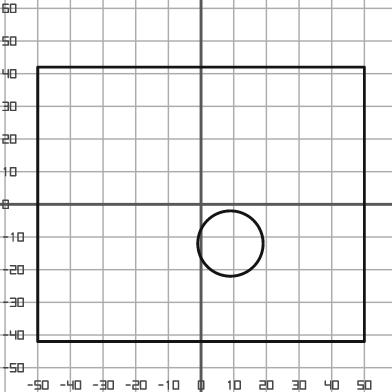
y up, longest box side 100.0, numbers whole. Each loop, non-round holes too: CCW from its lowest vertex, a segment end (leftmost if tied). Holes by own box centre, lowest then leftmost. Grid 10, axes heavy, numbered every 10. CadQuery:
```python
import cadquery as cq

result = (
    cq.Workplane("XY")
    .moveTo(-50.0, -42.0)
    .lineTo(50.0, -42.0)
    .lineTo(50.0, 42.0)
    .lineTo(-50.0, 42.0)
    .close()
    .moveTo(9.0, -12.0)
    .circle(10.0)
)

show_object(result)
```